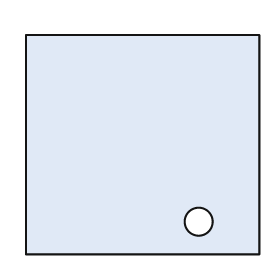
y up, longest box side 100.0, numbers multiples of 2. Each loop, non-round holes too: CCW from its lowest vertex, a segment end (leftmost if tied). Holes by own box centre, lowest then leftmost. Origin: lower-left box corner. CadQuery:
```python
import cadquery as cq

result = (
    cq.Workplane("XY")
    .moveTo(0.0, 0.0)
    .lineTo(100.0, 0.0)
    .lineTo(100.0, 94.0)
    .lineTo(0.0, 94.0)
    .close()
    .moveTo(74.0, 14.0)
    .circle(6.0)
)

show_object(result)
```